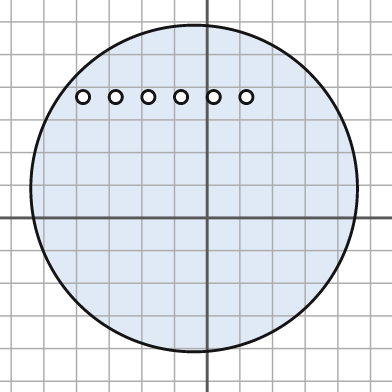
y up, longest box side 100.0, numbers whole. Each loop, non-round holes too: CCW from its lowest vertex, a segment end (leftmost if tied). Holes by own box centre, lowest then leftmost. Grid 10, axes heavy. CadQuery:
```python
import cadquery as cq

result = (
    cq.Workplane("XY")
    .moveTo(-4.0, 9.0)
    .circle(50.0)
    .moveTo(-38.0, 37.0)
    .circle(2.0)
    .moveTo(-28.0, 37.0)
    .circle(2.0)
    .moveTo(-18.0, 37.0)
    .circle(2.0)
    .moveTo(-8.0, 37.0)
    .circle(2.0)
    .moveTo(2.0, 37.0)
    .circle(2.0)
    .moveTo(12.0, 37.0)
    .circle(2.0)
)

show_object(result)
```